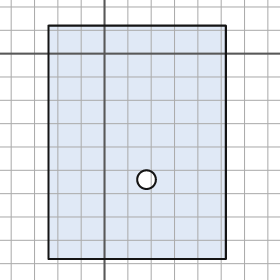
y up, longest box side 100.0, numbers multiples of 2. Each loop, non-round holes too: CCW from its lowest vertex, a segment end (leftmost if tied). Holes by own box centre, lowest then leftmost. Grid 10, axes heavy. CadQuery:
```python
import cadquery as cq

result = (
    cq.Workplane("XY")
    .moveTo(-24.0, -88.0)
    .lineTo(52.0, -88.0)
    .lineTo(52.0, 12.0)
    .lineTo(-24.0, 12.0)
    .close()
    .moveTo(18.0, -54.0)
    .circle(4.0)
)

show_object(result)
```